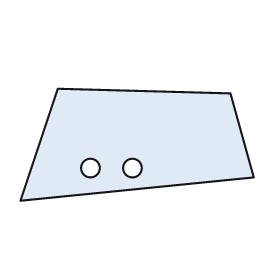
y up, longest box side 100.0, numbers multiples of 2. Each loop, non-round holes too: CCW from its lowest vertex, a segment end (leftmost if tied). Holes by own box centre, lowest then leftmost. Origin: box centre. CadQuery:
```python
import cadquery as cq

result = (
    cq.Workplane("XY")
    .moveTo(-50.0, -24.0)
    .lineTo(50.0, -14.0)
    .lineTo(40.0, 22.0)
    .lineTo(-34.0, 24.0)
    .close()
    .moveTo(-20.0, -10.0)
    .circle(4.0)
    .moveTo(-2.0, -10.0)
    .circle(4.0)
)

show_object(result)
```